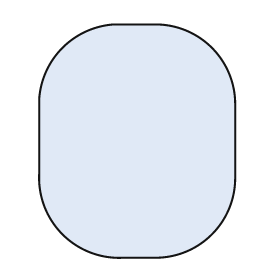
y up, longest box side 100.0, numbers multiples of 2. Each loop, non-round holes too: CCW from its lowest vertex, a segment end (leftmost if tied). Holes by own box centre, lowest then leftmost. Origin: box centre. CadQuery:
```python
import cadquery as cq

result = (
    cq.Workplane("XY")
    .moveTo(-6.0, -50.0)
    .lineTo(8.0, -50.0)
    .threePointArc((32.0, -40.0), (42.0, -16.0))
    .lineTo(42.0, 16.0)
    .threePointArc((32.0, 40.0), (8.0, 50.0))
    .lineTo(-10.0, 50.0)
    .threePointArc((-32.0, 40.0), (-42.0, 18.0))
    .lineTo(-42.0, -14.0)
    .threePointArc((-32.0, -40.0), (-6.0, -50.0))
    .close()
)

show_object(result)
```